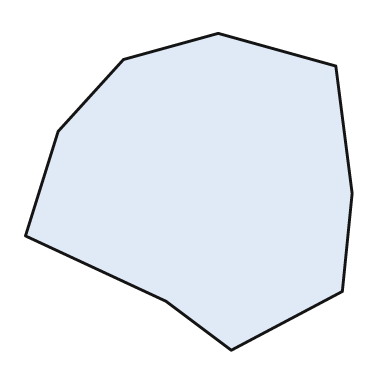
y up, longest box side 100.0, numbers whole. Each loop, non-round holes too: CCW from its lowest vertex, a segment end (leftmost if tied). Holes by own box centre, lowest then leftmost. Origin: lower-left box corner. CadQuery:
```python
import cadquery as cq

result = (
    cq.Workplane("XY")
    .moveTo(63.0, 0.0)
    .lineTo(97.0, 18.0)
    .lineTo(100.0, 48.0)
    .lineTo(95.0, 87.0)
    .lineTo(59.0, 97.0)
    .lineTo(30.0, 89.0)
    .lineTo(10.0, 67.0)
    .lineTo(0.0, 35.0)
    .lineTo(43.0, 15.0)
    .close()
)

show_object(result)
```